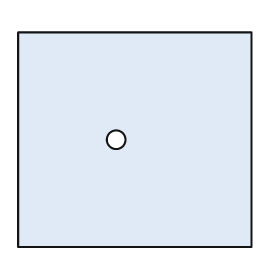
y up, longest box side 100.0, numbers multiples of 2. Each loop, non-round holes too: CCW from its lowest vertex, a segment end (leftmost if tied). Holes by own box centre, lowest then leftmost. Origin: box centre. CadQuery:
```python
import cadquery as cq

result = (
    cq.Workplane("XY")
    .moveTo(-50.0, -46.0)
    .lineTo(50.0, -46.0)
    .lineTo(50.0, 46.0)
    .lineTo(-50.0, 46.0)
    .close()
    .moveTo(-8.0, 0.0)
    .circle(4.0)
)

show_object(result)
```